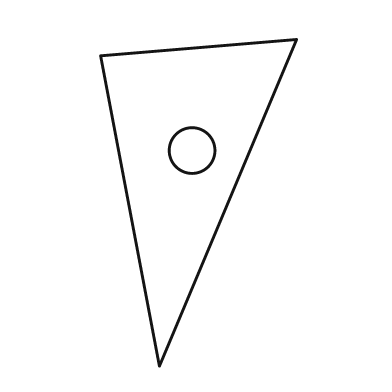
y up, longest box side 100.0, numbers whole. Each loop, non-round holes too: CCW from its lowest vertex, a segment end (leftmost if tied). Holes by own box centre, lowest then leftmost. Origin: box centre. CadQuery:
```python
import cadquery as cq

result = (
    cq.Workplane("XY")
    .moveTo(-12.0, -50.0)
    .lineTo(30.0, 50.0)
    .lineTo(-30.0, 45.0)
    .close()
    .moveTo(-2.0, 16.0)
    .circle(7.0)
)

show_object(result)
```